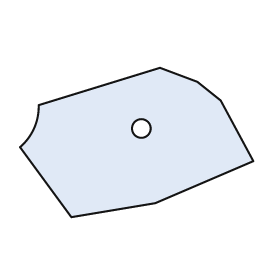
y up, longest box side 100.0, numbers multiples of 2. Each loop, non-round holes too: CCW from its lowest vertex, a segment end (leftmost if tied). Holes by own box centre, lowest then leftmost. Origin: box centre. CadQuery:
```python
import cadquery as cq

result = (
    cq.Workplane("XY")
    .moveTo(-28.0, -32.0)
    .lineTo(8.0, -26.0)
    .lineTo(50.0, -8.0)
    .lineTo(36.0, 18.0)
    .lineTo(26.0, 26.0)
    .lineTo(10.0, 32.0)
    .lineTo(-42.0, 16.0)
    .threePointArc((-44.0, 6.0), (-50.0, -2.0))
    .close()
    .moveTo(2.0, 6.0)
    .circle(4.0)
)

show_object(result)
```